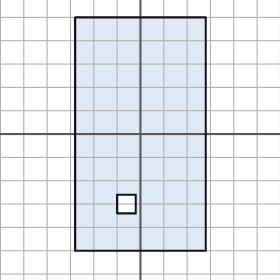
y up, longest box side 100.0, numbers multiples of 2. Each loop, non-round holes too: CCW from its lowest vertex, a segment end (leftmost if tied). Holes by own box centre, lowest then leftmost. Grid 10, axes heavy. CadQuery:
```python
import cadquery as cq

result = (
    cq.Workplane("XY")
    .moveTo(-28.0, -50.0)
    .lineTo(28.0, -50.0)
    .lineTo(28.0, 50.0)
    .lineTo(-28.0, 50.0)
    .close()
    .moveTo(-10.0, -34.0)
    .lineTo(-2.0, -34.0)
    .lineTo(-2.0, -26.0)
    .lineTo(-10.0, -26.0)
    .close()
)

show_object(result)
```